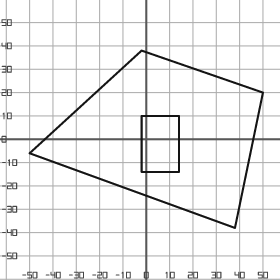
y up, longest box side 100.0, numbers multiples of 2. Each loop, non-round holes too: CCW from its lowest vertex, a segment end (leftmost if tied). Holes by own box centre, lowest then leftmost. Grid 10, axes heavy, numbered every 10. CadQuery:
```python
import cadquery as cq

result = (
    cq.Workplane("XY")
    .moveTo(38.0, -38.0)
    .lineTo(50.0, 20.0)
    .lineTo(-2.0, 38.0)
    .lineTo(-50.0, -6.0)
    .close()
    .moveTo(-2.0, -14.0)
    .lineTo(14.0, -14.0)
    .lineTo(14.0, 10.0)
    .lineTo(-2.0, 10.0)
    .close()
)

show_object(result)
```